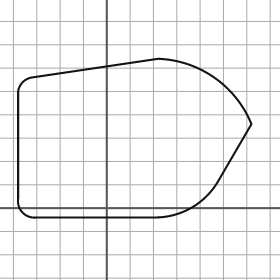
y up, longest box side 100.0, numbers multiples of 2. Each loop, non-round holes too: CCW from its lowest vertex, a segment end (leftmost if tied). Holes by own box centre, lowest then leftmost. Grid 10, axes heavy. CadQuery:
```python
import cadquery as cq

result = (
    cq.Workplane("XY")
    .moveTo(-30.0, -4.0)
    .lineTo(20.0, -4.0)
    .threePointArc((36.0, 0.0), (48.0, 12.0))
    .lineTo(62.0, 36.0)
    .threePointArc((46.0, 56.0), (22.0, 64.0))
    .lineTo(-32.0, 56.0)
    .threePointArc((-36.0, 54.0), (-38.0, 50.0))
    .lineTo(-38.0, 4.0)
    .threePointArc((-36.0, -2.0), (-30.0, -4.0))
    .close()
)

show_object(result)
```